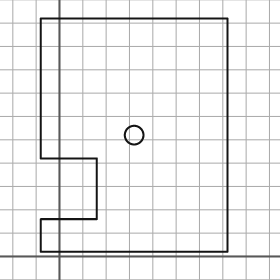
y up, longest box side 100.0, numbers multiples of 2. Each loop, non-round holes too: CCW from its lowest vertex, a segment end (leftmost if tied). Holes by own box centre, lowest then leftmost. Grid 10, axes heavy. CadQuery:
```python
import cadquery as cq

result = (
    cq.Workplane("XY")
    .moveTo(-8.0, 2.0)
    .lineTo(72.0, 2.0)
    .lineTo(72.0, 102.0)
    .lineTo(-8.0, 102.0)
    .lineTo(-8.0, 42.0)
    .lineTo(16.0, 42.0)
    .lineTo(16.0, 16.0)
    .lineTo(-8.0, 16.0)
    .close()
    .moveTo(32.0, 52.0)
    .circle(4.0)
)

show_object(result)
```